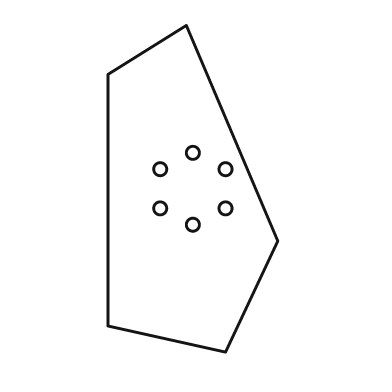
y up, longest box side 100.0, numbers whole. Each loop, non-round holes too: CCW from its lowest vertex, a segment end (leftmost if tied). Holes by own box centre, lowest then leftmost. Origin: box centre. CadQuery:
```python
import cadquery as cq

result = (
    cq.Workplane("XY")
    .moveTo(10.0, -50.0)
    .lineTo(26.0, -16.0)
    .lineTo(-2.0, 50.0)
    .lineTo(-26.0, 35.0)
    .lineTo(-26.0, -42.0)
    .close()
    .moveTo(0.0, -11.0)
    .circle(2.0)
    .moveTo(-10.0, -6.0)
    .circle(2.0)
    .moveTo(10.0, -6.0)
    .circle(2.0)
    .moveTo(-10.0, 6.0)
    .circle(2.0)
    .moveTo(10.0, 6.0)
    .circle(2.0)
    .moveTo(0.0, 11.0)
    .circle(2.0)
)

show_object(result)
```